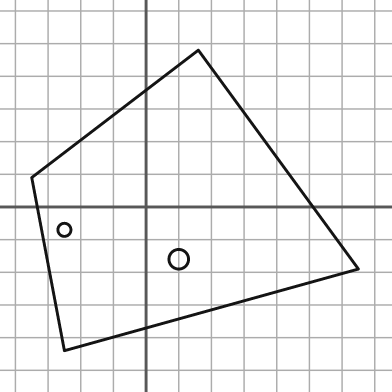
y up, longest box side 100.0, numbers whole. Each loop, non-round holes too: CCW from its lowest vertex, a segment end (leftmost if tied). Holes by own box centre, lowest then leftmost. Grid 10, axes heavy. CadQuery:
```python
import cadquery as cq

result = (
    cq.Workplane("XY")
    .moveTo(-25.0, -44.0)
    .lineTo(65.0, -19.0)
    .lineTo(16.0, 48.0)
    .lineTo(-35.0, 9.0)
    .close()
    .moveTo(10.0, -16.0)
    .circle(3.0)
    .moveTo(-25.0, -7.0)
    .circle(2.0)
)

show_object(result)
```